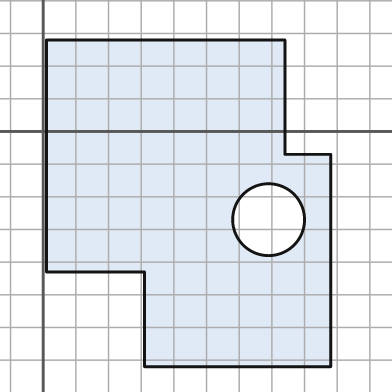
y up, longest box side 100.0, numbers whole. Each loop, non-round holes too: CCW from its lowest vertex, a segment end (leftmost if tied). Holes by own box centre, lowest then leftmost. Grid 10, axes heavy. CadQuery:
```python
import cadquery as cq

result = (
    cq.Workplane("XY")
    .moveTo(31.0, -72.0)
    .lineTo(88.0, -72.0)
    .lineTo(88.0, -7.0)
    .lineTo(74.0, -7.0)
    .lineTo(74.0, 28.0)
    .lineTo(1.0, 28.0)
    .lineTo(1.0, -43.0)
    .lineTo(31.0, -43.0)
    .close()
    .moveTo(69.0, -27.0)
    .circle(11.0)
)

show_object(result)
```